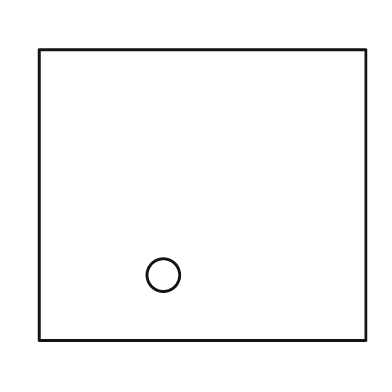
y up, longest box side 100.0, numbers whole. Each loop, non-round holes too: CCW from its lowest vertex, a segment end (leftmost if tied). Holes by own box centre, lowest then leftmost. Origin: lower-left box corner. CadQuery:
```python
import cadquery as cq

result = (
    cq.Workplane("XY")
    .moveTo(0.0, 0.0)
    .lineTo(100.0, 0.0)
    .lineTo(100.0, 89.0)
    .lineTo(0.0, 89.0)
    .close()
    .moveTo(38.0, 20.0)
    .circle(5.0)
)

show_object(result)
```